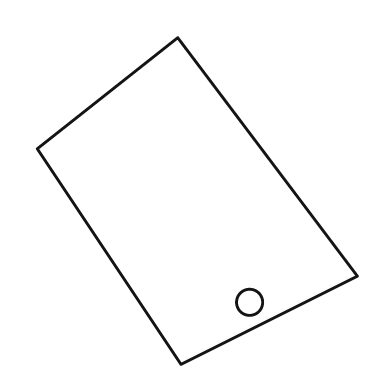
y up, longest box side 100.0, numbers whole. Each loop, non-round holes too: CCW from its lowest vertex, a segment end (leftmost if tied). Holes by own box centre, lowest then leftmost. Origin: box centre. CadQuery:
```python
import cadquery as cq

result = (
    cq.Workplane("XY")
    .moveTo(-5.0, -50.0)
    .lineTo(49.0, -23.0)
    .lineTo(-6.0, 50.0)
    .lineTo(-49.0, 16.0)
    .close()
    .moveTo(16.0, -31.0)
    .circle(4.0)
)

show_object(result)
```